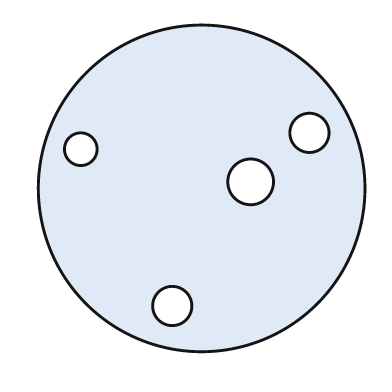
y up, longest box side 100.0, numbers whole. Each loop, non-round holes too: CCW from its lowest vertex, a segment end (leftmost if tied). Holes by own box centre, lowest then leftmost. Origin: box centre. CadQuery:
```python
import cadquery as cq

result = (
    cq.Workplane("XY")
    .moveTo(0.0, 0.0)
    .circle(50.0)
    .moveTo(-9.0, -36.0)
    .circle(6.0)
    .moveTo(15.0, 2.0)
    .circle(7.0)
    .moveTo(-37.0, 12.0)
    .circle(5.0)
    .moveTo(33.0, 17.0)
    .circle(6.0)
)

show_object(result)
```